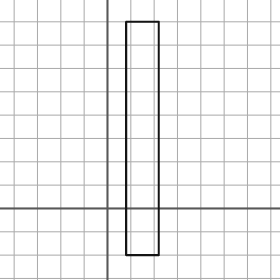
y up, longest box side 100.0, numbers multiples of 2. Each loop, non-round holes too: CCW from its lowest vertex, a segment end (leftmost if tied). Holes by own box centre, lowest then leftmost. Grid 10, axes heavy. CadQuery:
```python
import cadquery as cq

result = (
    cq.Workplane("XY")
    .moveTo(8.0, -20.0)
    .lineTo(22.0, -20.0)
    .lineTo(22.0, 80.0)
    .lineTo(8.0, 80.0)
    .close()
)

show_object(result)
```